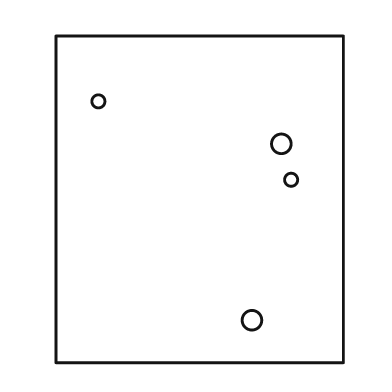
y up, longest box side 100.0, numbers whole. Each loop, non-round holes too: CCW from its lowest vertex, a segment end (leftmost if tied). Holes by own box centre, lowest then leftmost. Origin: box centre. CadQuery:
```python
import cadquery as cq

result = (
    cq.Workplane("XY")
    .moveTo(-44.0, -50.0)
    .lineTo(44.0, -50.0)
    .lineTo(44.0, 50.0)
    .lineTo(-44.0, 50.0)
    .close()
    .moveTo(16.0, -37.0)
    .circle(3.0)
    .moveTo(28.0, 6.0)
    .circle(2.0)
    .moveTo(25.0, 17.0)
    .circle(3.0)
    .moveTo(-31.0, 30.0)
    .circle(2.0)
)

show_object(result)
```